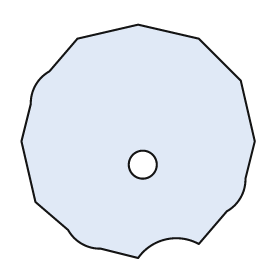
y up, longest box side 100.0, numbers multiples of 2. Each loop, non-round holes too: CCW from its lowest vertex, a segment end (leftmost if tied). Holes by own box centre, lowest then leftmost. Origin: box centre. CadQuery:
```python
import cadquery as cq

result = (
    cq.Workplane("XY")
    .moveTo(0.0, -50.0)
    .threePointArc((12.0, -42.0), (26.0, -44.0))
    .lineTo(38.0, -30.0)
    .threePointArc((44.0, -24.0), (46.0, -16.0))
    .lineTo(50.0, 0.0)
    .lineTo(44.0, 26.0)
    .lineTo(26.0, 44.0)
    .lineTo(0.0, 50.0)
    .lineTo(-26.0, 44.0)
    .lineTo(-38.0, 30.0)
    .threePointArc((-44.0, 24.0), (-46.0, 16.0))
    .lineTo(-50.0, 0.0)
    .lineTo(-44.0, -26.0)
    .lineTo(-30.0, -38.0)
    .threePointArc((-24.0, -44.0), (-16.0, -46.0))
    .close()
    .moveTo(2.0, -10.0)
    .circle(6.0)
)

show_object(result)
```